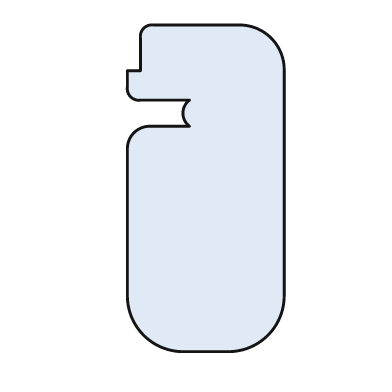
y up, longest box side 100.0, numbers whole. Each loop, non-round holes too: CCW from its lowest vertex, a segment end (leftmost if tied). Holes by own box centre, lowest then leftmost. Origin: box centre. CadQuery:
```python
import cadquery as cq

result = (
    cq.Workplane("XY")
    .moveTo(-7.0, -50.0)
    .lineTo(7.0, -50.0)
    .threePointArc((19.0, -45.0), (24.0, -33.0))
    .lineTo(24.0, 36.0)
    .threePointArc((20.0, 46.0), (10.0, 50.0))
    .lineTo(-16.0, 50.0)
    .threePointArc((-19.0, 49.0), (-20.0, 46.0))
    .lineTo(-20.0, 36.0)
    .lineTo(-24.0, 36.0)
    .lineTo(-24.0, 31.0)
    .threePointArc((-23.0, 28.0), (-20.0, 27.0))
    .lineTo(-5.0, 27.0)
    .threePointArc((-7.0, 23.0), (-5.0, 19.0))
    .lineTo(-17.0, 19.0)
    .threePointArc((-22.0, 17.0), (-24.0, 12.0))
    .lineTo(-24.0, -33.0)
    .threePointArc((-19.0, -45.0), (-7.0, -50.0))
    .close()
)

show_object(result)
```